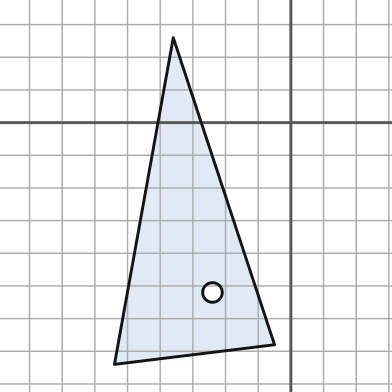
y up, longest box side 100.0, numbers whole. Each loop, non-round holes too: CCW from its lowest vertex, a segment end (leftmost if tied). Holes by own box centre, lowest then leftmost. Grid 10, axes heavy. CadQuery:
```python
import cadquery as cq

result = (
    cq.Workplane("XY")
    .moveTo(-54.0, -74.0)
    .lineTo(-5.0, -68.0)
    .lineTo(-36.0, 26.0)
    .close()
    .moveTo(-24.0, -52.0)
    .circle(3.0)
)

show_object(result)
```